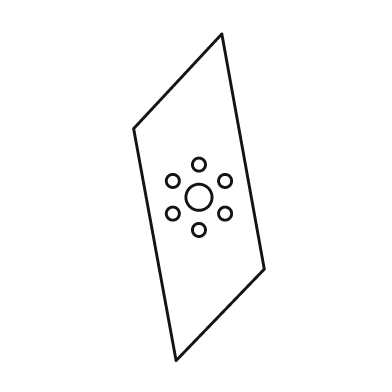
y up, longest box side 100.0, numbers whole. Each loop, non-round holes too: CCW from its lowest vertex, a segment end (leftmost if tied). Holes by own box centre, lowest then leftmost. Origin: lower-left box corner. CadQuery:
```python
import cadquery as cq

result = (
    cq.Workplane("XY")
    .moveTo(13.0, 0.0)
    .lineTo(40.0, 28.0)
    .lineTo(27.0, 100.0)
    .lineTo(0.0, 71.0)
    .close()
    .moveTo(20.0, 40.0)
    .circle(2.0)
    .moveTo(12.0, 45.0)
    .circle(2.0)
    .moveTo(28.0, 45.0)
    .circle(2.0)
    .moveTo(20.0, 50.0)
    .circle(4.0)
    .moveTo(12.0, 55.0)
    .circle(2.0)
    .moveTo(28.0, 55.0)
    .circle(2.0)
    .moveTo(20.0, 60.0)
    .circle(2.0)
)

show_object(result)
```